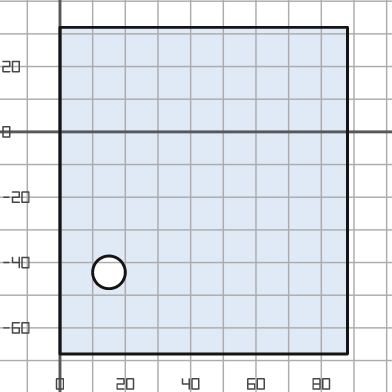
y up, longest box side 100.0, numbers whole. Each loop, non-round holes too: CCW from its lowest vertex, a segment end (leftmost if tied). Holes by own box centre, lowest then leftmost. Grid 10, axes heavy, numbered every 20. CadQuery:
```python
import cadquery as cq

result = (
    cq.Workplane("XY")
    .moveTo(0.0, -68.0)
    .lineTo(88.0, -68.0)
    .lineTo(88.0, 32.0)
    .lineTo(0.0, 32.0)
    .close()
    .moveTo(15.0, -43.0)
    .circle(5.0)
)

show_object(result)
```